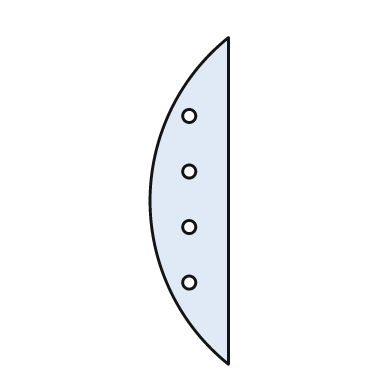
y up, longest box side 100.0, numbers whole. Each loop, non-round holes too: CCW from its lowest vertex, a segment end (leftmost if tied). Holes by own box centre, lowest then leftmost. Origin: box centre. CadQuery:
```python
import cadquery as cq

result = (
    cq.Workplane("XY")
    .moveTo(12.0, -50.0)
    .lineTo(12.0, 50.0)
    .threePointArc((-12.0, 0.0), (12.0, -50.0))
    .close()
    .moveTo(0.0, -25.0)
    .circle(2.0)
    .moveTo(0.0, -8.0)
    .circle(2.0)
    .moveTo(0.0, 9.0)
    .circle(2.0)
    .moveTo(0.0, 26.0)
    .circle(2.0)
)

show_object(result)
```